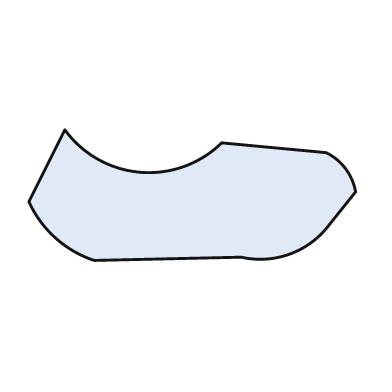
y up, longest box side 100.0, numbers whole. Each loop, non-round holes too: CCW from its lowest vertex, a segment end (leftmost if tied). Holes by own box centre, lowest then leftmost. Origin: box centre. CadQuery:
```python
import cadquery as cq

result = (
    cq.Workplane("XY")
    .moveTo(-30.0, -20.0)
    .lineTo(15.0, -19.0)
    .threePointArc((30.0, -18.0), (42.0, -9.0))
    .lineTo(50.0, 1.0)
    .threePointArc((47.0, 8.0), (41.0, 13.0))
    .lineTo(9.0, 16.0)
    .threePointArc((-16.0, 7.0), (-39.0, 20.0))
    .lineTo(-50.0, -2.0)
    .threePointArc((-42.0, -13.0), (-30.0, -20.0))
    .close()
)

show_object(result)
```